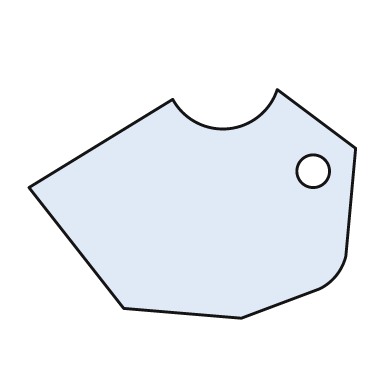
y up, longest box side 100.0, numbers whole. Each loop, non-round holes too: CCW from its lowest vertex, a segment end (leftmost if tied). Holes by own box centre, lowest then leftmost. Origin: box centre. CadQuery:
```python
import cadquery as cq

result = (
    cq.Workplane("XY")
    .moveTo(15.0, -35.0)
    .lineTo(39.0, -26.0)
    .threePointArc((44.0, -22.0), (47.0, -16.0))
    .lineTo(50.0, 17.0)
    .lineTo(26.0, 35.0)
    .threePointArc((11.0, 23.0), (-6.0, 32.0))
    .lineTo(-50.0, 5.0)
    .lineTo(-21.0, -32.0)
    .close()
    .moveTo(37.0, 10.0)
    .circle(5.0)
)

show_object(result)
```